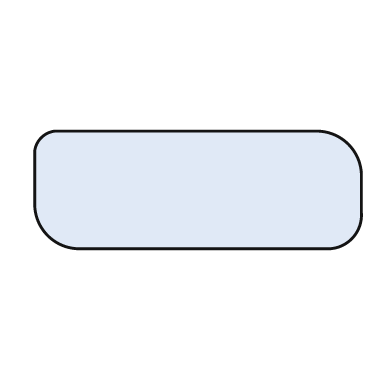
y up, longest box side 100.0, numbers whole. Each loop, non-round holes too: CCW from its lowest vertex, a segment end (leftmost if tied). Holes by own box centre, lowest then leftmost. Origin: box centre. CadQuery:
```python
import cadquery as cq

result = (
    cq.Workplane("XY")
    .moveTo(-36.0, -18.0)
    .lineTo(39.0, -18.0)
    .threePointArc((47.0, -15.0), (50.0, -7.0))
    .lineTo(50.0, 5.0)
    .threePointArc((46.0, 14.0), (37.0, 18.0))
    .lineTo(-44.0, 18.0)
    .threePointArc((-48.0, 16.0), (-50.0, 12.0))
    .lineTo(-50.0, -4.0)
    .threePointArc((-46.0, -14.0), (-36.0, -18.0))
    .close()
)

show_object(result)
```